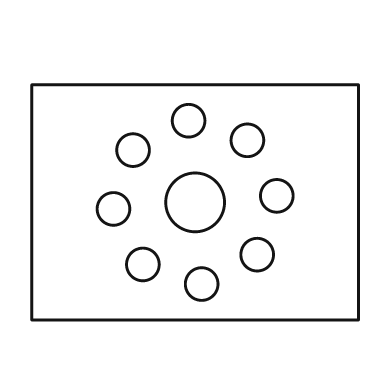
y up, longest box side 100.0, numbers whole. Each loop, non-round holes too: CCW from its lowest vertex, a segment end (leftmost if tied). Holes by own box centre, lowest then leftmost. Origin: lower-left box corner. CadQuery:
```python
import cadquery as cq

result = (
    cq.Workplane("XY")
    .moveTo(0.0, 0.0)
    .lineTo(100.0, 0.0)
    .lineTo(100.0, 72.0)
    .lineTo(0.0, 72.0)
    .close()
    .moveTo(52.0, 11.0)
    .circle(5.0)
    .moveTo(34.0, 17.0)
    .circle(5.0)
    .moveTo(69.0, 20.0)
    .circle(5.0)
    .moveTo(25.0, 34.0)
    .circle(5.0)
    .moveTo(50.0, 36.0)
    .circle(9.0)
    .moveTo(75.0, 38.0)
    .circle(5.0)
    .moveTo(31.0, 52.0)
    .circle(5.0)
    .moveTo(66.0, 55.0)
    .circle(5.0)
    .moveTo(48.0, 61.0)
    .circle(5.0)
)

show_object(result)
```